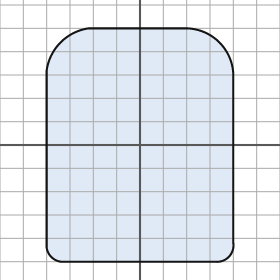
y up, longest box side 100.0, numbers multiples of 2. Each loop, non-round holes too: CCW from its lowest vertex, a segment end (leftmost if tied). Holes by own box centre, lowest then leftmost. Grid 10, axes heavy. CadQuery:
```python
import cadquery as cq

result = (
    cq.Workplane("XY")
    .moveTo(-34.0, -50.0)
    .lineTo(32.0, -50.0)
    .threePointArc((38.0, -48.0), (40.0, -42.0))
    .lineTo(40.0, 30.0)
    .threePointArc((34.0, 44.0), (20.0, 50.0))
    .lineTo(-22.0, 50.0)
    .threePointArc((-34.0, 44.0), (-40.0, 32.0))
    .lineTo(-40.0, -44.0)
    .threePointArc((-38.0, -48.0), (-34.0, -50.0))
    .close()
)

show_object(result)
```